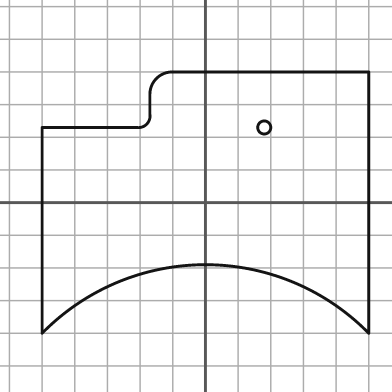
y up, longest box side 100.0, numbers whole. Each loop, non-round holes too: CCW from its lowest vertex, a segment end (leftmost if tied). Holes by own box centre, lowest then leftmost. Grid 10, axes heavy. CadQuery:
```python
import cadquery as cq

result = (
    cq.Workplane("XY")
    .moveTo(-50.0, -40.0)
    .threePointArc((0.0, -19.0), (50.0, -40.0))
    .lineTo(50.0, 40.0)
    .lineTo(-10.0, 40.0)
    .threePointArc((-15.0, 38.0), (-17.0, 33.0))
    .lineTo(-17.0, 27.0)
    .threePointArc((-18.0, 24.0), (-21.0, 23.0))
    .lineTo(-50.0, 23.0)
    .close()
    .moveTo(18.0, 23.0)
    .circle(2.0)
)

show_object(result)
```